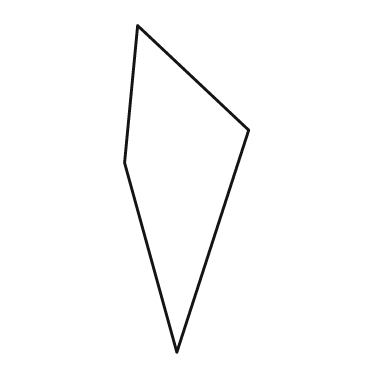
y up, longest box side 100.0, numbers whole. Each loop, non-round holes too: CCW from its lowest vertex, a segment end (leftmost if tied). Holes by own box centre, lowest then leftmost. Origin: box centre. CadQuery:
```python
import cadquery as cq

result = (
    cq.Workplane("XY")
    .moveTo(-3.0, -50.0)
    .lineTo(19.0, 18.0)
    .lineTo(-15.0, 50.0)
    .lineTo(-19.0, 8.0)
    .close()
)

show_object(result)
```